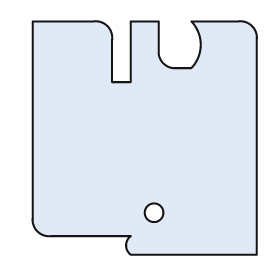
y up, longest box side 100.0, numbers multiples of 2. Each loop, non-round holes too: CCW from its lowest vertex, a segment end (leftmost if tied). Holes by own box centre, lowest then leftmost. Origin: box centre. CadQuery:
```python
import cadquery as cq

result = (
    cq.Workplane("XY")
    .moveTo(-6.0, -50.0)
    .lineTo(48.0, -50.0)
    .lineTo(48.0, 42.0)
    .threePointArc((46.0, 48.0), (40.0, 50.0))
    .lineTo(20.0, 50.0)
    .threePointArc((24.0, 40.0), (20.0, 30.0))
    .lineTo(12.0, 30.0)
    .threePointArc((8.0, 32.0), (6.0, 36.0))
    .lineTo(6.0, 50.0)
    .lineTo(-6.0, 50.0)
    .lineTo(-6.0, 24.0)
    .lineTo(-14.0, 24.0)
    .lineTo(-14.0, 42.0)
    .threePointArc((-16.0, 48.0), (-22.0, 50.0))
    .lineTo(-48.0, 50.0)
    .lineTo(-48.0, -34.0)
    .threePointArc((-46.0, -40.0), (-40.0, -42.0))
    .lineTo(-6.0, -42.0)
    .threePointArc((-8.0, -46.0), (-6.0, -50.0))
    .close()
    .moveTo(4.0, -32.0)
    .circle(4.0)
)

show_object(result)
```